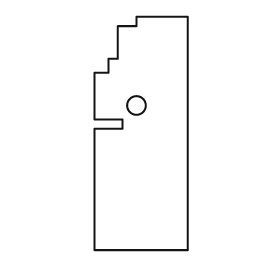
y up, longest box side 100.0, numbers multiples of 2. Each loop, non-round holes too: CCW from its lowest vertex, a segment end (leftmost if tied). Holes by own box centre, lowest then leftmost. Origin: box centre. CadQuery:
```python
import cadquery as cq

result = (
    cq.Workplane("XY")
    .moveTo(-20.0, -50.0)
    .lineTo(20.0, -50.0)
    .lineTo(20.0, 50.0)
    .lineTo(-2.0, 50.0)
    .lineTo(-2.0, 46.0)
    .lineTo(-10.0, 46.0)
    .lineTo(-10.0, 32.0)
    .lineTo(-14.0, 32.0)
    .lineTo(-14.0, 26.0)
    .lineTo(-20.0, 26.0)
    .lineTo(-20.0, 6.0)
    .lineTo(-8.0, 6.0)
    .lineTo(-8.0, 2.0)
    .lineTo(-20.0, 2.0)
    .close()
    .moveTo(-2.0, 12.0)
    .circle(4.0)
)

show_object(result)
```